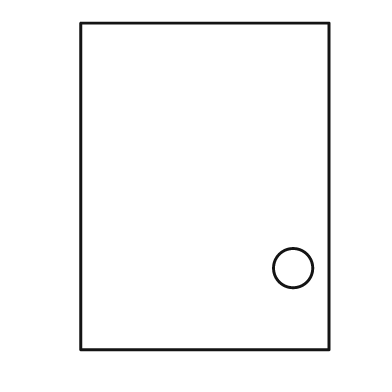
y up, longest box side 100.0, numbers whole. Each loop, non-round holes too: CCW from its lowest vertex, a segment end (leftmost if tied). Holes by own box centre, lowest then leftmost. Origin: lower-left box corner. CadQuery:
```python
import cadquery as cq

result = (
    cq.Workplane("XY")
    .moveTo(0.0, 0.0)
    .lineTo(76.0, 0.0)
    .lineTo(76.0, 100.0)
    .lineTo(0.0, 100.0)
    .close()
    .moveTo(65.0, 25.0)
    .circle(6.0)
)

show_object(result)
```